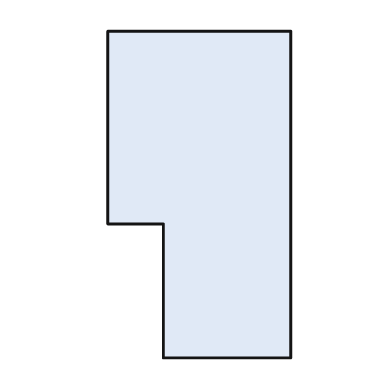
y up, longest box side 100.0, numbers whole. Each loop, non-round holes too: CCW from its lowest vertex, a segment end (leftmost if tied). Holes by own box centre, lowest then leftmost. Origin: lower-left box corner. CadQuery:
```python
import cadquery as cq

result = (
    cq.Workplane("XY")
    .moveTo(17.0, 0.0)
    .lineTo(56.0, 0.0)
    .lineTo(56.0, 100.0)
    .lineTo(0.0, 100.0)
    .lineTo(0.0, 41.0)
    .lineTo(17.0, 41.0)
    .close()
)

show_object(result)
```